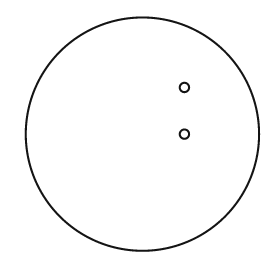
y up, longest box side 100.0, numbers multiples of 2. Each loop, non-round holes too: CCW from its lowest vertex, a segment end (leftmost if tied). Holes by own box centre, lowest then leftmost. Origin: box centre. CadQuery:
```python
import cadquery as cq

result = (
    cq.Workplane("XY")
    .moveTo(0.0, 0.0)
    .circle(50.0)
    .moveTo(18.0, 0.0)
    .circle(2.0)
    .moveTo(18.0, 20.0)
    .circle(2.0)
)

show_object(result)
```